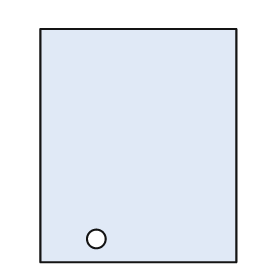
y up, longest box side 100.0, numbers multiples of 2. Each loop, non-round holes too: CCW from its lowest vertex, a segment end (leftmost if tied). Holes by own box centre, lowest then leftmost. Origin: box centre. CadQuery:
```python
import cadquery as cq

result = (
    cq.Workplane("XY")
    .moveTo(-42.0, -50.0)
    .lineTo(42.0, -50.0)
    .lineTo(42.0, 50.0)
    .lineTo(-42.0, 50.0)
    .close()
    .moveTo(-18.0, -40.0)
    .circle(4.0)
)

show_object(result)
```